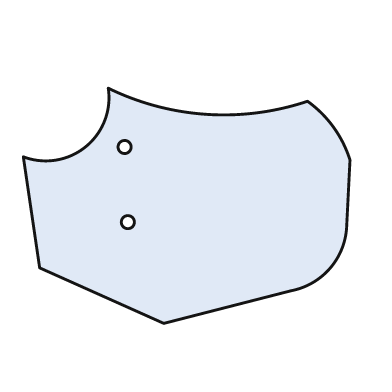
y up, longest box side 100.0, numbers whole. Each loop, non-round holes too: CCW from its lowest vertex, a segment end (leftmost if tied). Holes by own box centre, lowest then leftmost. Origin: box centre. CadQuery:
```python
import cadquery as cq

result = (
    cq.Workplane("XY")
    .moveTo(-7.0, -36.0)
    .lineTo(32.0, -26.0)
    .threePointArc((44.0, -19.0), (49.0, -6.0))
    .lineTo(50.0, 14.0)
    .threePointArc((45.0, 24.0), (37.0, 32.0))
    .threePointArc((6.0, 28.0), (-24.0, 36.0))
    .threePointArc((-31.0, 18.0), (-50.0, 15.0))
    .lineTo(-45.0, -19.0)
    .close()
    .moveTo(-18.0, -5.0)
    .circle(2.0)
    .moveTo(-19.0, 18.0)
    .circle(2.0)
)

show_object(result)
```